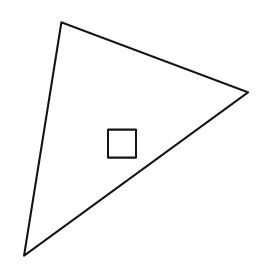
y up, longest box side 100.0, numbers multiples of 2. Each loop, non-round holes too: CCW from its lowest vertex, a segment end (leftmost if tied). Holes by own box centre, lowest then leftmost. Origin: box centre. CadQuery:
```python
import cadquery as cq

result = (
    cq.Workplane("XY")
    .moveTo(-48.0, -50.0)
    .lineTo(48.0, 20.0)
    .lineTo(-32.0, 50.0)
    .close()
    .moveTo(-12.0, -8.0)
    .lineTo(0.0, -8.0)
    .lineTo(0.0, 4.0)
    .lineTo(-12.0, 4.0)
    .close()
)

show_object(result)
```